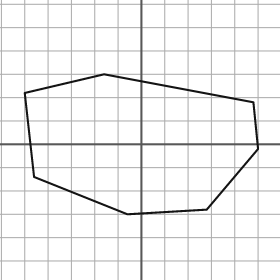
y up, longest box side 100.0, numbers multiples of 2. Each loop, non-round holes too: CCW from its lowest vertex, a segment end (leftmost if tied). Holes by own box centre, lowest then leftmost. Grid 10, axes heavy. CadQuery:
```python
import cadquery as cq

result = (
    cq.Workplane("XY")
    .moveTo(-6.0, -30.0)
    .lineTo(28.0, -28.0)
    .lineTo(50.0, -2.0)
    .lineTo(48.0, 18.0)
    .lineTo(-16.0, 30.0)
    .lineTo(-50.0, 22.0)
    .lineTo(-46.0, -14.0)
    .close()
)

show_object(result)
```